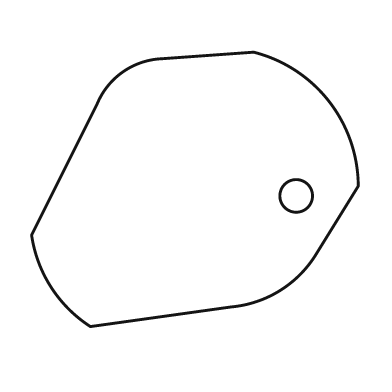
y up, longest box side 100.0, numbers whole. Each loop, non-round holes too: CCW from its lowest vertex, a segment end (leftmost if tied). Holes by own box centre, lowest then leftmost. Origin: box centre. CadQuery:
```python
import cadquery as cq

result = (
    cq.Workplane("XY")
    .moveTo(-32.0, -42.0)
    .lineTo(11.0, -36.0)
    .threePointArc((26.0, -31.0), (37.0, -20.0))
    .lineTo(50.0, 1.0)
    .threePointArc((41.0, 27.0), (18.0, 42.0))
    .lineTo(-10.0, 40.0)
    .threePointArc((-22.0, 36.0), (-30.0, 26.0))
    .lineTo(-50.0, -14.0)
    .threePointArc((-44.0, -30.0), (-32.0, -42.0))
    .close()
    .moveTo(31.0, -2.0)
    .circle(5.0)
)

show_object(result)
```